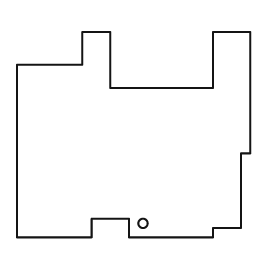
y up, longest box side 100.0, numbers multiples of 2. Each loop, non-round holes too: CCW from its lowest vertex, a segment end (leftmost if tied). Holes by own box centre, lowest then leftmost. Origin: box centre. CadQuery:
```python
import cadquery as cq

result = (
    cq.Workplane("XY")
    .moveTo(-50.0, -44.0)
    .lineTo(-18.0, -44.0)
    .lineTo(-18.0, -36.0)
    .lineTo(-2.0, -36.0)
    .lineTo(-2.0, -44.0)
    .lineTo(34.0, -44.0)
    .lineTo(34.0, -40.0)
    .lineTo(46.0, -40.0)
    .lineTo(46.0, -8.0)
    .lineTo(50.0, -8.0)
    .lineTo(50.0, 44.0)
    .lineTo(34.0, 44.0)
    .lineTo(34.0, 20.0)
    .lineTo(-10.0, 20.0)
    .lineTo(-10.0, 44.0)
    .lineTo(-22.0, 44.0)
    .lineTo(-22.0, 30.0)
    .lineTo(-50.0, 30.0)
    .close()
    .moveTo(4.0, -38.0)
    .circle(2.0)
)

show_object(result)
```